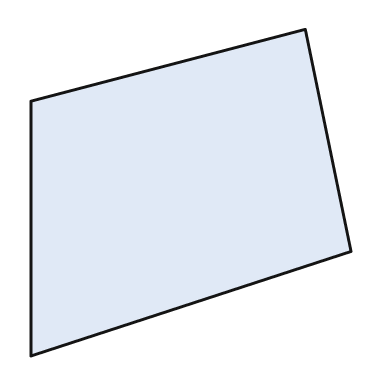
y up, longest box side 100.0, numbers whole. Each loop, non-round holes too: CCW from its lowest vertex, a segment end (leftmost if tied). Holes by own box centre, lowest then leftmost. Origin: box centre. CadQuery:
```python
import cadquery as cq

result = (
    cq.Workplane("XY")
    .moveTo(-49.0, -50.0)
    .lineTo(49.0, -18.0)
    .lineTo(35.0, 50.0)
    .lineTo(-49.0, 28.0)
    .close()
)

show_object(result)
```